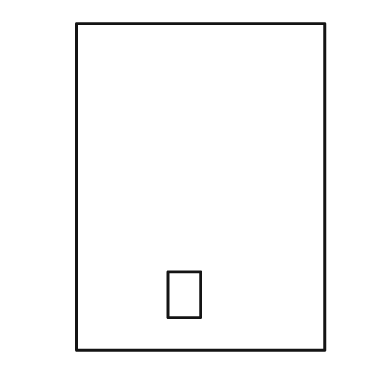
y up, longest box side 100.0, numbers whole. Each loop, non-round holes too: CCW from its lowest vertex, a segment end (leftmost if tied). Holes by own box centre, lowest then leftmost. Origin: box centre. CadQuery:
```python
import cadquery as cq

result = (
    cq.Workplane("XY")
    .moveTo(-38.0, -50.0)
    .lineTo(38.0, -50.0)
    .lineTo(38.0, 50.0)
    .lineTo(-38.0, 50.0)
    .close()
    .moveTo(-10.0, -40.0)
    .lineTo(0.0, -40.0)
    .lineTo(0.0, -26.0)
    .lineTo(-10.0, -26.0)
    .close()
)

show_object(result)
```